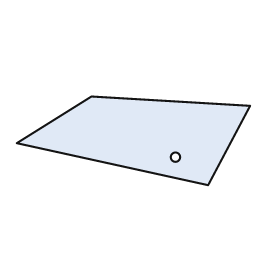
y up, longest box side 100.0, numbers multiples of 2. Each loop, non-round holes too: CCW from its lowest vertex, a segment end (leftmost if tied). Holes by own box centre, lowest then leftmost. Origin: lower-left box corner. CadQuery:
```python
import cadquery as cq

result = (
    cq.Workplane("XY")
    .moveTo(82.0, 0.0)
    .lineTo(100.0, 34.0)
    .lineTo(32.0, 38.0)
    .lineTo(0.0, 18.0)
    .close()
    .moveTo(68.0, 12.0)
    .circle(2.0)
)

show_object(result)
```